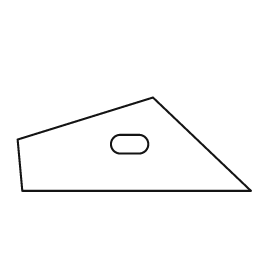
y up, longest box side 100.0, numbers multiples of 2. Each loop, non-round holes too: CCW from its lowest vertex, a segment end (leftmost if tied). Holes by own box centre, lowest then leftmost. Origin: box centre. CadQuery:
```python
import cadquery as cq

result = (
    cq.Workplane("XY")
    .moveTo(-48.0, -20.0)
    .lineTo(50.0, -20.0)
    .lineTo(8.0, 20.0)
    .lineTo(-50.0, 2.0)
    .close()
    .moveTo(-6.0, -4.0)
    .lineTo(2.0, -4.0)
    .threePointArc((6.0, 0.0), (2.0, 4.0))
    .lineTo(-6.0, 4.0)
    .threePointArc((-10.0, 0.0), (-6.0, -4.0))
    .close()
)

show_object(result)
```